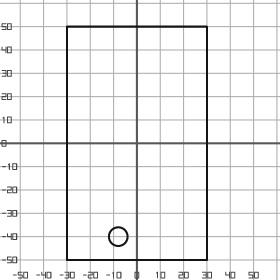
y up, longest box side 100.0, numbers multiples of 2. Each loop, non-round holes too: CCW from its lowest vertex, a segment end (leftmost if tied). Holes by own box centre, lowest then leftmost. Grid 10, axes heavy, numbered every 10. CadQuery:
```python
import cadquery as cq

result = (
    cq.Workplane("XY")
    .moveTo(-30.0, -50.0)
    .lineTo(30.0, -50.0)
    .lineTo(30.0, 50.0)
    .lineTo(-30.0, 50.0)
    .close()
    .moveTo(-8.0, -40.0)
    .circle(4.0)
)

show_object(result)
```